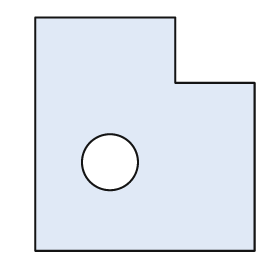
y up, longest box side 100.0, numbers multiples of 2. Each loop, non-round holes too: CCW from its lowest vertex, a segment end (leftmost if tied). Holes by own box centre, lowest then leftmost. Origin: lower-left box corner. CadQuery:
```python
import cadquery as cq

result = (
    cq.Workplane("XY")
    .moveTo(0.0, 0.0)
    .lineTo(94.0, 0.0)
    .lineTo(94.0, 72.0)
    .lineTo(60.0, 72.0)
    .lineTo(60.0, 100.0)
    .lineTo(0.0, 100.0)
    .close()
    .moveTo(32.0, 38.0)
    .circle(12.0)
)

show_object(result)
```